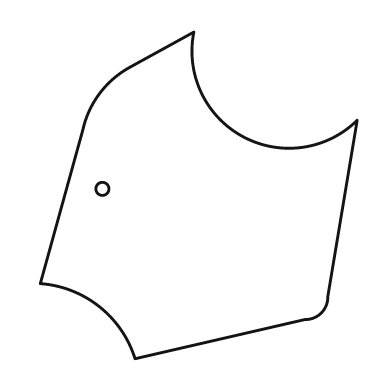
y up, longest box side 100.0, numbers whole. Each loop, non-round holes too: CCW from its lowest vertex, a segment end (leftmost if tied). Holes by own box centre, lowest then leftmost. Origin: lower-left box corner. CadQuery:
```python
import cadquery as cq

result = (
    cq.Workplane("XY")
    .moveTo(29.0, 0.0)
    .lineTo(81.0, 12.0)
    .threePointArc((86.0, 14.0), (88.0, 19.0))
    .lineTo(97.0, 73.0)
    .threePointArc((62.0, 68.0), (47.0, 100.0))
    .lineTo(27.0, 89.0)
    .threePointArc((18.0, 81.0), (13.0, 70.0))
    .lineTo(0.0, 23.0)
    .threePointArc((18.0, 16.0), (29.0, 0.0))
    .close()
    .moveTo(19.0, 52.0)
    .circle(2.0)
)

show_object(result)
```